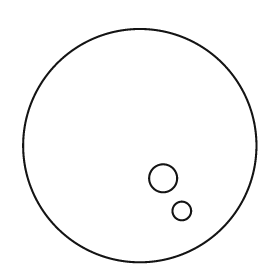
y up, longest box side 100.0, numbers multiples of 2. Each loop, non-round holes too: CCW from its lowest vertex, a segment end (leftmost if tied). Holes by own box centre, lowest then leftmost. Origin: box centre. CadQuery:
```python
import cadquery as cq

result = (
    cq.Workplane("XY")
    .moveTo(0.0, 0.0)
    .circle(50.0)
    .moveTo(18.0, -28.0)
    .circle(4.0)
    .moveTo(10.0, -14.0)
    .circle(6.0)
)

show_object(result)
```